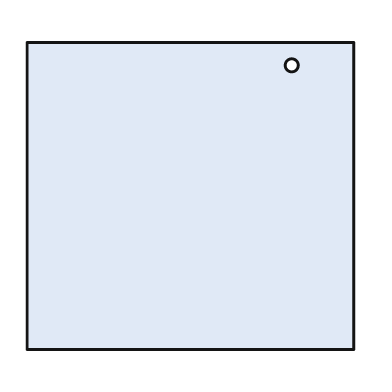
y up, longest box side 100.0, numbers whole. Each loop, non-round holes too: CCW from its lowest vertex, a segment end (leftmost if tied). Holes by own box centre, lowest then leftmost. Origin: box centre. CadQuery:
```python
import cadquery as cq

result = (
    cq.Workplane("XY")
    .moveTo(-50.0, -47.0)
    .lineTo(50.0, -47.0)
    .lineTo(50.0, 47.0)
    .lineTo(-50.0, 47.0)
    .close()
    .moveTo(31.0, 40.0)
    .circle(2.0)
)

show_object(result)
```